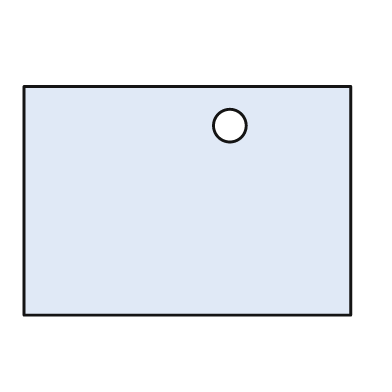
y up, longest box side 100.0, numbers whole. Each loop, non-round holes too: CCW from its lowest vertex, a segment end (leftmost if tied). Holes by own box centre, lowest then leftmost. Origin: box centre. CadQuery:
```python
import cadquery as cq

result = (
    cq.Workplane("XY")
    .moveTo(-50.0, -35.0)
    .lineTo(50.0, -35.0)
    .lineTo(50.0, 35.0)
    .lineTo(-50.0, 35.0)
    .close()
    .moveTo(13.0, 23.0)
    .circle(5.0)
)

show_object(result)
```